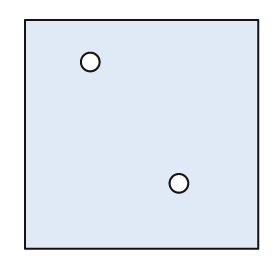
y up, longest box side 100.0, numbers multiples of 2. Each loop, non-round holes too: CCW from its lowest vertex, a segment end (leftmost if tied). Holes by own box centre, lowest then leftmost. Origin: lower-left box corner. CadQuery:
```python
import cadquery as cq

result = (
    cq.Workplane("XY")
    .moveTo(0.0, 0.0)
    .lineTo(100.0, 0.0)
    .lineTo(100.0, 98.0)
    .lineTo(0.0, 98.0)
    .close()
    .moveTo(66.0, 28.0)
    .circle(4.0)
    .moveTo(28.0, 80.0)
    .circle(4.0)
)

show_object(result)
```